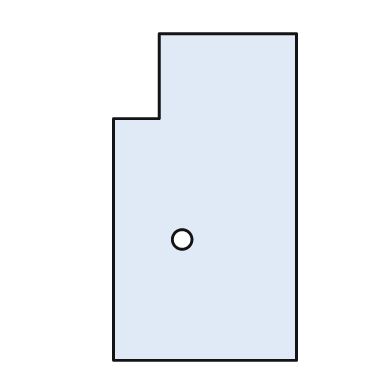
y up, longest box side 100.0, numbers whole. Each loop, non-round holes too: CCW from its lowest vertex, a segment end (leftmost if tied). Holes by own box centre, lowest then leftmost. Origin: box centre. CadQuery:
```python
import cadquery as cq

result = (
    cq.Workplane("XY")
    .moveTo(-28.0, -50.0)
    .lineTo(28.0, -50.0)
    .lineTo(28.0, 50.0)
    .lineTo(-14.0, 50.0)
    .lineTo(-14.0, 24.0)
    .lineTo(-28.0, 24.0)
    .close()
    .moveTo(-7.0, -13.0)
    .circle(3.0)
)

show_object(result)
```